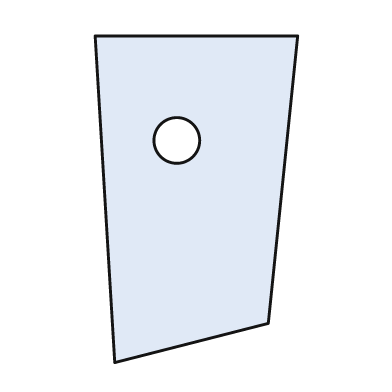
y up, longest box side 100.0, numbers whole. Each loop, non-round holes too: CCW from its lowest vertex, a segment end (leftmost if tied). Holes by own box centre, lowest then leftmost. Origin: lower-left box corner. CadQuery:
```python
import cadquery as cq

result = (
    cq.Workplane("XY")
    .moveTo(6.0, 0.0)
    .lineTo(53.0, 12.0)
    .lineTo(62.0, 100.0)
    .lineTo(0.0, 100.0)
    .close()
    .moveTo(25.0, 68.0)
    .circle(7.0)
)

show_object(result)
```